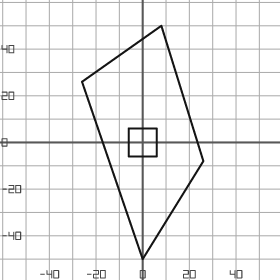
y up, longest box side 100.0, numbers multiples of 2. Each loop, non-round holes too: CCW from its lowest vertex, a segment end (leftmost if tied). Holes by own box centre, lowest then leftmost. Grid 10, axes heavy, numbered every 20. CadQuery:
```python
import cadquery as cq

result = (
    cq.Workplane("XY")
    .moveTo(0.0, -50.0)
    .lineTo(26.0, -8.0)
    .lineTo(8.0, 50.0)
    .lineTo(-26.0, 26.0)
    .close()
    .moveTo(-6.0, -6.0)
    .lineTo(6.0, -6.0)
    .lineTo(6.0, 6.0)
    .lineTo(-6.0, 6.0)
    .close()
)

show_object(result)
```